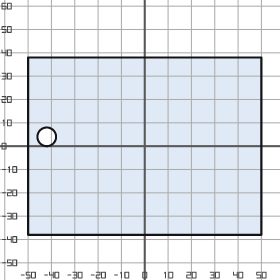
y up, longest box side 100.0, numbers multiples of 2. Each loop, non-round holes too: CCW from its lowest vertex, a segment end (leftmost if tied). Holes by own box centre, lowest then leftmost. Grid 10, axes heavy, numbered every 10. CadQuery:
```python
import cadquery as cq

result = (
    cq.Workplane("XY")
    .moveTo(-50.0, -38.0)
    .lineTo(50.0, -38.0)
    .lineTo(50.0, 38.0)
    .lineTo(-50.0, 38.0)
    .close()
    .moveTo(-42.0, 4.0)
    .circle(4.0)
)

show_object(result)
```